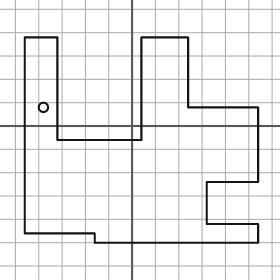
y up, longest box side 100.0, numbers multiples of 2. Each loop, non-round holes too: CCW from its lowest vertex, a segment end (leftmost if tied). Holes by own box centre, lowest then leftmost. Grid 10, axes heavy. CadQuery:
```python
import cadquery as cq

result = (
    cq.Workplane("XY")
    .moveTo(-16.0, -50.0)
    .lineTo(54.0, -50.0)
    .lineTo(54.0, -42.0)
    .lineTo(32.0, -42.0)
    .lineTo(32.0, -24.0)
    .lineTo(54.0, -24.0)
    .lineTo(54.0, 8.0)
    .lineTo(24.0, 8.0)
    .lineTo(24.0, 38.0)
    .lineTo(4.0, 38.0)
    .lineTo(4.0, -6.0)
    .lineTo(-32.0, -6.0)
    .lineTo(-32.0, 38.0)
    .lineTo(-46.0, 38.0)
    .lineTo(-46.0, -46.0)
    .lineTo(-16.0, -46.0)
    .close()
    .moveTo(-38.0, 8.0)
    .circle(2.0)
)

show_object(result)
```